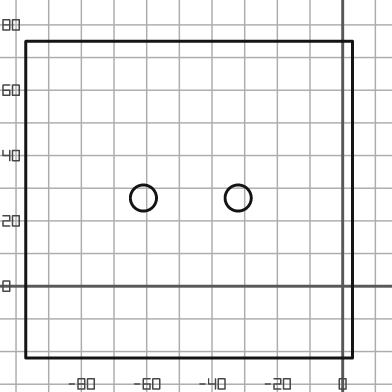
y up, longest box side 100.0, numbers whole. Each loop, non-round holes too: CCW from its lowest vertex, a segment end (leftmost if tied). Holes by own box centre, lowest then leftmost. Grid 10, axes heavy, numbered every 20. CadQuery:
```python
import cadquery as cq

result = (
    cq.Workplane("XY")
    .moveTo(-97.0, -22.0)
    .lineTo(3.0, -22.0)
    .lineTo(3.0, 75.0)
    .lineTo(-97.0, 75.0)
    .close()
    .moveTo(-61.0, 27.0)
    .circle(4.0)
    .moveTo(-32.0, 27.0)
    .circle(4.0)
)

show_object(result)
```